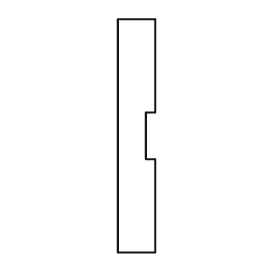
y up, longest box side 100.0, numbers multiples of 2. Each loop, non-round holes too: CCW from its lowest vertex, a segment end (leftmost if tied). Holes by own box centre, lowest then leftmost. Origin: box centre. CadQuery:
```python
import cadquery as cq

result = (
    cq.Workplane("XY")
    .moveTo(-8.0, -50.0)
    .lineTo(8.0, -50.0)
    .lineTo(8.0, -10.0)
    .lineTo(4.0, -10.0)
    .lineTo(4.0, 10.0)
    .lineTo(8.0, 10.0)
    .lineTo(8.0, 50.0)
    .lineTo(-8.0, 50.0)
    .close()
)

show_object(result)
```